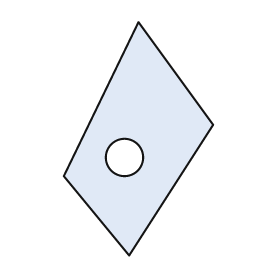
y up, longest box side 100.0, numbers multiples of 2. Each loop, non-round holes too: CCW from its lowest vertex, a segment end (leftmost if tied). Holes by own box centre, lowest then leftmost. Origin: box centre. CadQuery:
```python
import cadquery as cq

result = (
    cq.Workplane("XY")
    .moveTo(-4.0, -50.0)
    .lineTo(32.0, 6.0)
    .lineTo(0.0, 50.0)
    .lineTo(-32.0, -16.0)
    .close()
    .moveTo(-6.0, -8.0)
    .circle(8.0)
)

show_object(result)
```